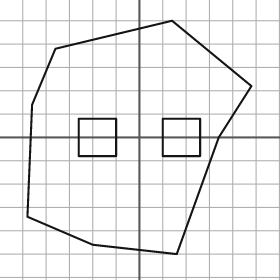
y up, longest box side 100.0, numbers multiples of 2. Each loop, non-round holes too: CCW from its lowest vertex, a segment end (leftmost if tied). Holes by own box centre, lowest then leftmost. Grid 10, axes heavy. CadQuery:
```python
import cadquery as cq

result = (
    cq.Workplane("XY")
    .moveTo(16.0, -50.0)
    .lineTo(34.0, 0.0)
    .lineTo(48.0, 22.0)
    .lineTo(14.0, 50.0)
    .lineTo(-36.0, 38.0)
    .lineTo(-46.0, 14.0)
    .lineTo(-48.0, -34.0)
    .lineTo(-20.0, -46.0)
    .close()
    .moveTo(-26.0, -8.0)
    .lineTo(-10.0, -8.0)
    .lineTo(-10.0, 8.0)
    .lineTo(-26.0, 8.0)
    .close()
    .moveTo(10.0, -8.0)
    .lineTo(26.0, -8.0)
    .lineTo(26.0, 8.0)
    .lineTo(10.0, 8.0)
    .close()
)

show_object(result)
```